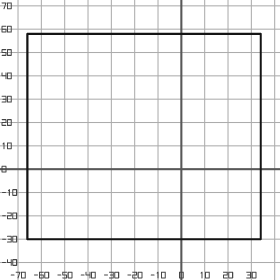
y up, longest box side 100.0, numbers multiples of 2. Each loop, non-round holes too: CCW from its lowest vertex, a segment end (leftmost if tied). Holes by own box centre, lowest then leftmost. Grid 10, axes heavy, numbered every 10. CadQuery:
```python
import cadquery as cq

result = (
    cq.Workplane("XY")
    .moveTo(-66.0, -30.0)
    .lineTo(34.0, -30.0)
    .lineTo(34.0, 58.0)
    .lineTo(-66.0, 58.0)
    .close()
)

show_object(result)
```